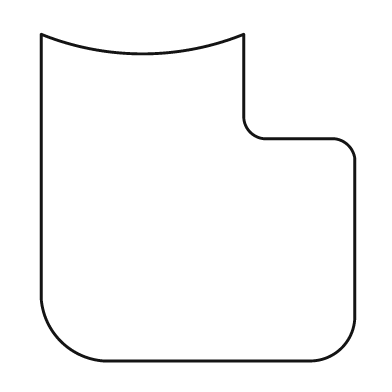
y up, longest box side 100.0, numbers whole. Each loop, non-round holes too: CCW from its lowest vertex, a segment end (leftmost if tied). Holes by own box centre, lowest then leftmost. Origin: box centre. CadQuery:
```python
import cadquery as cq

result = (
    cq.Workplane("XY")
    .moveTo(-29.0, -50.0)
    .lineTo(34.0, -50.0)
    .threePointArc((44.0, -46.0), (48.0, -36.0))
    .lineTo(48.0, 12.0)
    .threePointArc((46.0, 16.0), (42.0, 18.0))
    .lineTo(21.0, 18.0)
    .threePointArc((16.0, 20.0), (14.0, 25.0))
    .lineTo(14.0, 50.0)
    .threePointArc((-17.0, 44.0), (-48.0, 50.0))
    .lineTo(-48.0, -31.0)
    .threePointArc((-42.0, -44.0), (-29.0, -50.0))
    .close()
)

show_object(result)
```